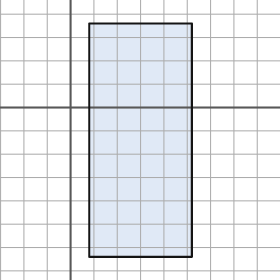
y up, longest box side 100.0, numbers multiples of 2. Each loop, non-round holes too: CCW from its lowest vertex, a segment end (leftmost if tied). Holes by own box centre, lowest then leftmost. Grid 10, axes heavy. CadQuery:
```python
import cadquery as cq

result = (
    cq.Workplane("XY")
    .moveTo(8.0, -64.0)
    .lineTo(52.0, -64.0)
    .lineTo(52.0, 36.0)
    .lineTo(8.0, 36.0)
    .close()
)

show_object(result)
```